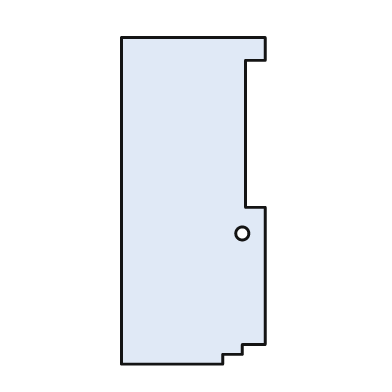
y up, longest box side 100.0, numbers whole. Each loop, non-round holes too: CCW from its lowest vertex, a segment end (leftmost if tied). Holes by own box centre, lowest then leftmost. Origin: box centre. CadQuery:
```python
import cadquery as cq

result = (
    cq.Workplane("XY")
    .moveTo(-22.0, -50.0)
    .lineTo(9.0, -50.0)
    .lineTo(9.0, -47.0)
    .lineTo(15.0, -47.0)
    .lineTo(15.0, -44.0)
    .lineTo(22.0, -44.0)
    .lineTo(22.0, -2.0)
    .lineTo(16.0, -2.0)
    .lineTo(16.0, 43.0)
    .lineTo(22.0, 43.0)
    .lineTo(22.0, 50.0)
    .lineTo(-22.0, 50.0)
    .close()
    .moveTo(15.0, -10.0)
    .circle(2.0)
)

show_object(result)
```